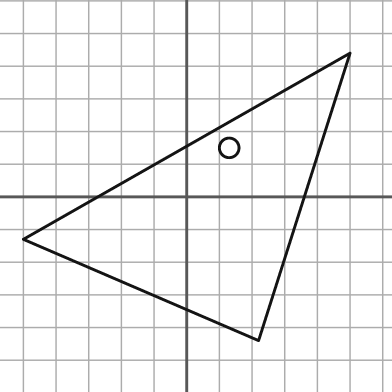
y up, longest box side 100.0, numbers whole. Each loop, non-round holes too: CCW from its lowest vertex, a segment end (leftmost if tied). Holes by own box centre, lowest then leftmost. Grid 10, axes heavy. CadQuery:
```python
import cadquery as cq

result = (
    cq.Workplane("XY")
    .moveTo(22.0, -44.0)
    .lineTo(50.0, 44.0)
    .lineTo(-50.0, -13.0)
    .close()
    .moveTo(13.0, 15.0)
    .circle(3.0)
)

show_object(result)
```